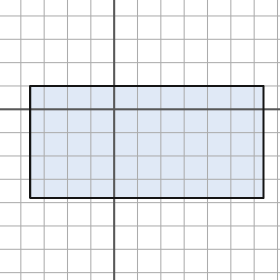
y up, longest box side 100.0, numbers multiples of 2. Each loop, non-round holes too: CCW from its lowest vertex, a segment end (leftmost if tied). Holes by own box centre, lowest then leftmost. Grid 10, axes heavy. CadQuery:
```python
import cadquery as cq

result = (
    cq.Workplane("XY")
    .moveTo(-36.0, -38.0)
    .lineTo(64.0, -38.0)
    .lineTo(64.0, 10.0)
    .lineTo(-36.0, 10.0)
    .close()
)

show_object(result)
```